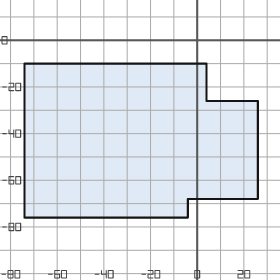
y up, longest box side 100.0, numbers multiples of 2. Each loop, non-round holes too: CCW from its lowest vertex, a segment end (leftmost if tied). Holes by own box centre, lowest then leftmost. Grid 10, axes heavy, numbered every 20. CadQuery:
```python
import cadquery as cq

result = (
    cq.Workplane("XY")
    .moveTo(-74.0, -76.0)
    .lineTo(-4.0, -76.0)
    .lineTo(-4.0, -68.0)
    .lineTo(26.0, -68.0)
    .lineTo(26.0, -26.0)
    .lineTo(4.0, -26.0)
    .lineTo(4.0, -10.0)
    .lineTo(-74.0, -10.0)
    .close()
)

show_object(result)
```